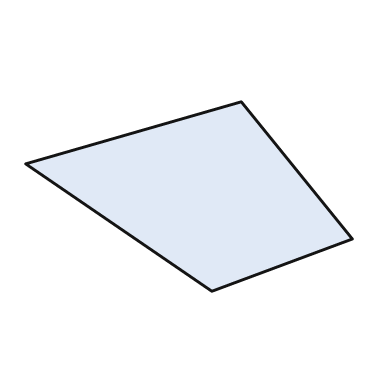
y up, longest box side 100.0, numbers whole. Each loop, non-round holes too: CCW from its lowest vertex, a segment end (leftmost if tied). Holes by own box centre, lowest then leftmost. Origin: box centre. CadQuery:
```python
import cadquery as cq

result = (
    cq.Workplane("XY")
    .moveTo(7.0, -29.0)
    .lineTo(50.0, -13.0)
    .lineTo(16.0, 29.0)
    .lineTo(-50.0, 10.0)
    .close()
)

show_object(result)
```